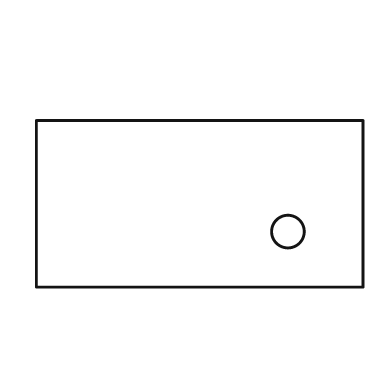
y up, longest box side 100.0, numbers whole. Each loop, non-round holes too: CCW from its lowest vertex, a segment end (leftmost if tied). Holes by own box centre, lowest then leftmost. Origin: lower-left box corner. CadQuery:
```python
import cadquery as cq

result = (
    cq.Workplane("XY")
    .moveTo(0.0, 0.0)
    .lineTo(100.0, 0.0)
    .lineTo(100.0, 51.0)
    .lineTo(0.0, 51.0)
    .close()
    .moveTo(77.0, 17.0)
    .circle(5.0)
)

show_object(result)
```